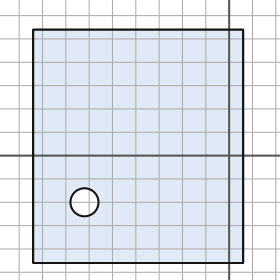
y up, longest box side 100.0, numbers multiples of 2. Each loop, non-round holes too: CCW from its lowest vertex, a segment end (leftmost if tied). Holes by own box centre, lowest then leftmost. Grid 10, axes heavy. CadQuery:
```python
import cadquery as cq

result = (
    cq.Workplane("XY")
    .moveTo(-84.0, -46.0)
    .lineTo(6.0, -46.0)
    .lineTo(6.0, 54.0)
    .lineTo(-84.0, 54.0)
    .close()
    .moveTo(-62.0, -20.0)
    .circle(6.0)
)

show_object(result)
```